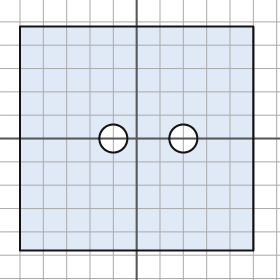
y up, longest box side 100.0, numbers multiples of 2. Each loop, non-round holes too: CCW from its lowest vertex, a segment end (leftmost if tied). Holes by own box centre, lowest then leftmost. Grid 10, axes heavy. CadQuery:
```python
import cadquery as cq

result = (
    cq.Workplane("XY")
    .moveTo(-50.0, -48.0)
    .lineTo(50.0, -48.0)
    .lineTo(50.0, 48.0)
    .lineTo(-50.0, 48.0)
    .close()
    .moveTo(-10.0, 0.0)
    .circle(6.0)
    .moveTo(20.0, 0.0)
    .circle(6.0)
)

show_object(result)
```